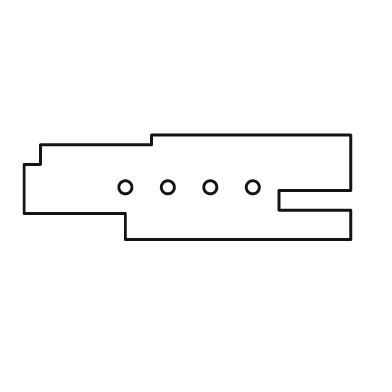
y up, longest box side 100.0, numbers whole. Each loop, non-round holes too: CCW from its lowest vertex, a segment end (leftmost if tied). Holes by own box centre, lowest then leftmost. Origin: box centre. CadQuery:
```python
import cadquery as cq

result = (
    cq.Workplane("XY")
    .moveTo(-19.0, -16.0)
    .lineTo(50.0, -16.0)
    .lineTo(50.0, -7.0)
    .lineTo(28.0, -7.0)
    .lineTo(28.0, -1.0)
    .lineTo(50.0, -1.0)
    .lineTo(50.0, 16.0)
    .lineTo(-11.0, 16.0)
    .lineTo(-11.0, 13.0)
    .lineTo(-45.0, 13.0)
    .lineTo(-45.0, 7.0)
    .lineTo(-50.0, 7.0)
    .lineTo(-50.0, -8.0)
    .lineTo(-19.0, -8.0)
    .close()
    .moveTo(-19.0, 0.0)
    .circle(2.0)
    .moveTo(-6.0, 0.0)
    .circle(2.0)
    .moveTo(7.0, 0.0)
    .circle(2.0)
    .moveTo(20.0, 0.0)
    .circle(2.0)
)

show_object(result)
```